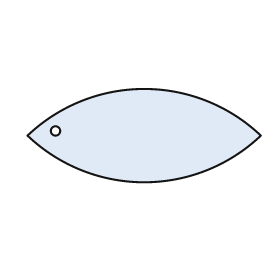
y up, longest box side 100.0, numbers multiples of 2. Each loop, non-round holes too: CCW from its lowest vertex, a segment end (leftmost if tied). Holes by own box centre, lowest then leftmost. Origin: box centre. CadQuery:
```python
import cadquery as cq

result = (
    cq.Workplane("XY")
    .moveTo(-50.0, 0.0)
    .threePointArc((0.0, -20.0), (50.0, 0.0))
    .threePointArc((0.0, 20.0), (-50.0, 0.0))
    .close()
    .moveTo(-38.0, 2.0)
    .circle(2.0)
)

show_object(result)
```